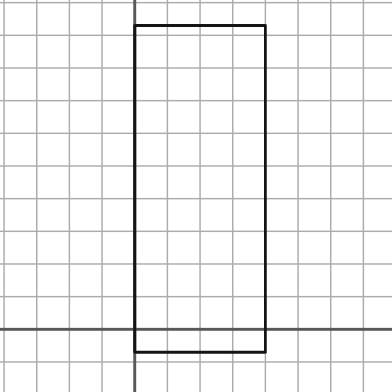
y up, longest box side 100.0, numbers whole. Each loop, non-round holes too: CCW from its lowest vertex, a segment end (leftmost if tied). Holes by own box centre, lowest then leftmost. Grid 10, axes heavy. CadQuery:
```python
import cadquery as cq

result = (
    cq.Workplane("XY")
    .moveTo(0.0, -7.0)
    .lineTo(40.0, -7.0)
    .lineTo(40.0, 93.0)
    .lineTo(0.0, 93.0)
    .close()
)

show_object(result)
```